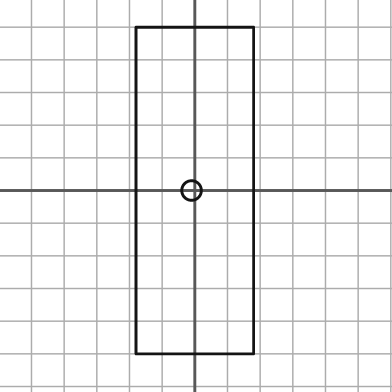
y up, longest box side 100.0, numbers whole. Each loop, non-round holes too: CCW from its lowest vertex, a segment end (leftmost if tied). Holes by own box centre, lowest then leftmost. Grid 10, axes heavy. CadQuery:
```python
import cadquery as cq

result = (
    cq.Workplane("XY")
    .moveTo(-18.0, -50.0)
    .lineTo(18.0, -50.0)
    .lineTo(18.0, 50.0)
    .lineTo(-18.0, 50.0)
    .close()
    .moveTo(-1.0, 0.0)
    .circle(3.0)
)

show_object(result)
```